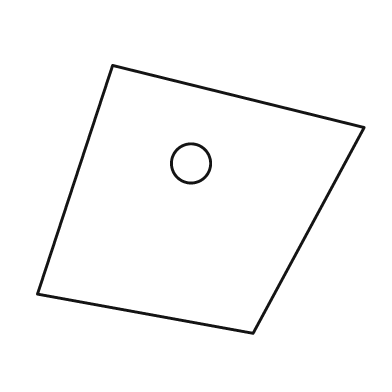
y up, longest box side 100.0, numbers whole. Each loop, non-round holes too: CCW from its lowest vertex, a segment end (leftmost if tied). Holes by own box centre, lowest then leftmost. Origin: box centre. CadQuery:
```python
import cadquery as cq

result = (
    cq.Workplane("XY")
    .moveTo(16.0, -41.0)
    .lineTo(50.0, 22.0)
    .lineTo(-27.0, 41.0)
    .lineTo(-50.0, -29.0)
    .close()
    .moveTo(-3.0, 11.0)
    .circle(6.0)
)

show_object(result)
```